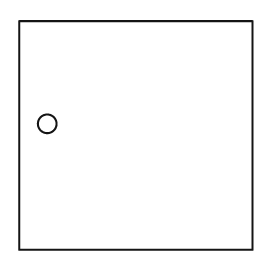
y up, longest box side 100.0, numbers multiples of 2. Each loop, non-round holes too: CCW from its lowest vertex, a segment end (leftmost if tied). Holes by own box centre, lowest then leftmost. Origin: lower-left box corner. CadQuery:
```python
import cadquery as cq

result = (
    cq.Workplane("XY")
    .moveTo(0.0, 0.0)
    .lineTo(100.0, 0.0)
    .lineTo(100.0, 98.0)
    .lineTo(0.0, 98.0)
    .close()
    .moveTo(12.0, 54.0)
    .circle(4.0)
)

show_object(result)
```